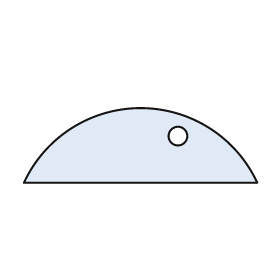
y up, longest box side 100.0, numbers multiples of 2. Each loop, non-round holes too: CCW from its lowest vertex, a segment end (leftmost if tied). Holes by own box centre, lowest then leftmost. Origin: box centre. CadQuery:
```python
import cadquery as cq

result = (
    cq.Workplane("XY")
    .moveTo(-50.0, -16.0)
    .lineTo(50.0, -16.0)
    .threePointArc((0.0, 16.0), (-50.0, -16.0))
    .close()
    .moveTo(16.0, 4.0)
    .circle(4.0)
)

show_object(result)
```